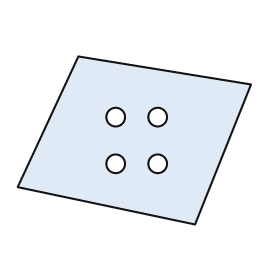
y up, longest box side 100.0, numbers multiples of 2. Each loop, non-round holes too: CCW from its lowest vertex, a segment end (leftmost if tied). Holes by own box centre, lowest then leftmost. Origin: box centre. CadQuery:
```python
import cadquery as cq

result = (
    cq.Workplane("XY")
    .moveTo(26.0, -36.0)
    .lineTo(50.0, 24.0)
    .lineTo(-24.0, 36.0)
    .lineTo(-50.0, -20.0)
    .close()
    .moveTo(-8.0, -10.0)
    .circle(4.0)
    .moveTo(10.0, -10.0)
    .circle(4.0)
    .moveTo(-8.0, 10.0)
    .circle(4.0)
    .moveTo(10.0, 10.0)
    .circle(4.0)
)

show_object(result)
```